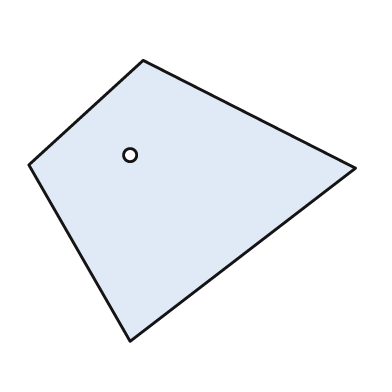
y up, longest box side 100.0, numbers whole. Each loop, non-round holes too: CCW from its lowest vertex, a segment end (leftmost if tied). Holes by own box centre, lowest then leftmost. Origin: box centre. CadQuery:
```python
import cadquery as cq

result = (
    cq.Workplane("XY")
    .moveTo(-19.0, -43.0)
    .lineTo(50.0, 10.0)
    .lineTo(-15.0, 43.0)
    .lineTo(-50.0, 11.0)
    .close()
    .moveTo(-19.0, 14.0)
    .circle(2.0)
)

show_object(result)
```